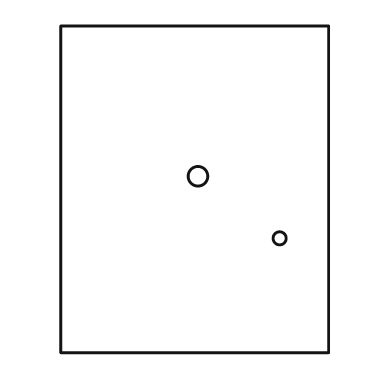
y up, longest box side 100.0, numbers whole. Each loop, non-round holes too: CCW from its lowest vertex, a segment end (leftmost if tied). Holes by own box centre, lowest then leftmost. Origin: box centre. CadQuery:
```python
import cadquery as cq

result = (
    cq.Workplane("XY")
    .moveTo(-41.0, -50.0)
    .lineTo(41.0, -50.0)
    .lineTo(41.0, 50.0)
    .lineTo(-41.0, 50.0)
    .close()
    .moveTo(26.0, -15.0)
    .circle(2.0)
    .moveTo(1.0, 4.0)
    .circle(3.0)
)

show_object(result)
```